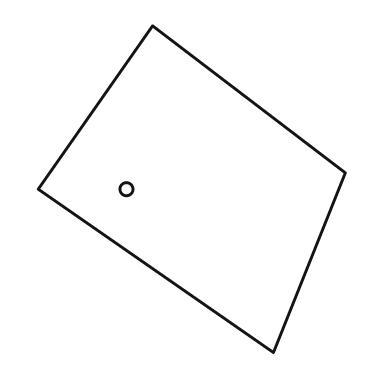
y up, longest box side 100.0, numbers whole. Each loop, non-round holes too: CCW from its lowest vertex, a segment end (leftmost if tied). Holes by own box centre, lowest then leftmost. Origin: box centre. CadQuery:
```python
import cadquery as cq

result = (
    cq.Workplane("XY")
    .moveTo(25.0, -50.0)
    .lineTo(47.0, 5.0)
    .lineTo(-12.0, 50.0)
    .lineTo(-47.0, 0.0)
    .close()
    .moveTo(-20.0, 0.0)
    .circle(2.0)
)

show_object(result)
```